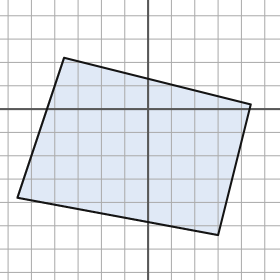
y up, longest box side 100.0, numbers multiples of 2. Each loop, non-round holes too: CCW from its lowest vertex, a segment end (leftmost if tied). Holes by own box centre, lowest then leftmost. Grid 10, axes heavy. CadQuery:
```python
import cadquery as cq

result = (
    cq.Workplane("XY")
    .moveTo(30.0, -54.0)
    .lineTo(44.0, 2.0)
    .lineTo(-36.0, 22.0)
    .lineTo(-56.0, -38.0)
    .close()
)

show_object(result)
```